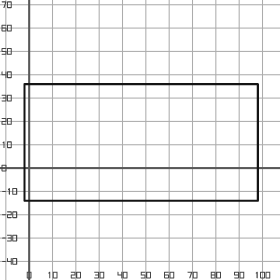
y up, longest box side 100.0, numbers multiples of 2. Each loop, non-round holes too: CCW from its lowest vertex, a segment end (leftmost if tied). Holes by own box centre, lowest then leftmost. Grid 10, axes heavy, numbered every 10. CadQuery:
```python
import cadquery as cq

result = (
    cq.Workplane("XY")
    .moveTo(-2.0, -14.0)
    .lineTo(98.0, -14.0)
    .lineTo(98.0, 36.0)
    .lineTo(-2.0, 36.0)
    .close()
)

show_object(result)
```